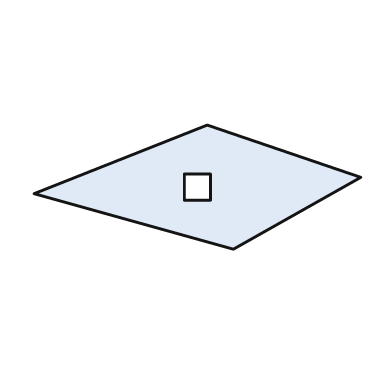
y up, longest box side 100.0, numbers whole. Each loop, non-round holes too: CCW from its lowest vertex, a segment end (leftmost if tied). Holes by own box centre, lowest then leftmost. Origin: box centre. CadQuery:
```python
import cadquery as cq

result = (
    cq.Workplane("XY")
    .moveTo(11.0, -19.0)
    .lineTo(50.0, 3.0)
    .lineTo(3.0, 19.0)
    .lineTo(-50.0, -2.0)
    .close()
    .moveTo(-4.0, -4.0)
    .lineTo(4.0, -4.0)
    .lineTo(4.0, 4.0)
    .lineTo(-4.0, 4.0)
    .close()
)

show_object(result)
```